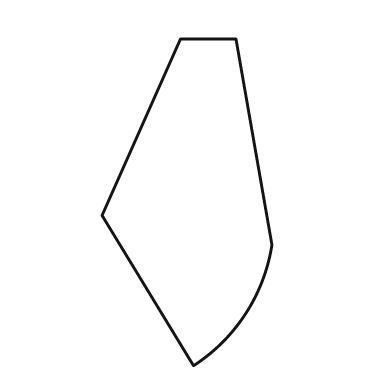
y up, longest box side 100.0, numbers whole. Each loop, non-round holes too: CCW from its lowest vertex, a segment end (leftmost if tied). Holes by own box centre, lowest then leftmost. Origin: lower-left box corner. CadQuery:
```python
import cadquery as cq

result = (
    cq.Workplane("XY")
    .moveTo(28.0, 0.0)
    .threePointArc((44.0, 16.0), (52.0, 37.0))
    .lineTo(41.0, 100.0)
    .lineTo(24.0, 100.0)
    .lineTo(0.0, 46.0)
    .close()
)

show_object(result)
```